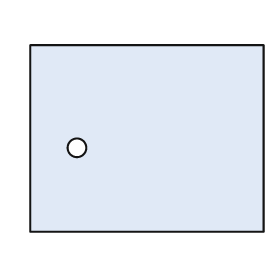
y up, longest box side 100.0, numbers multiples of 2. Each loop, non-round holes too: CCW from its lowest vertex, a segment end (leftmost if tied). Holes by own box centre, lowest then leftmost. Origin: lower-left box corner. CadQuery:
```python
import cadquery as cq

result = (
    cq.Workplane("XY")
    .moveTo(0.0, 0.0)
    .lineTo(100.0, 0.0)
    .lineTo(100.0, 80.0)
    .lineTo(0.0, 80.0)
    .close()
    .moveTo(20.0, 36.0)
    .circle(4.0)
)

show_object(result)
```